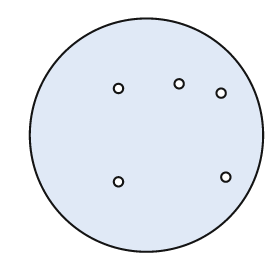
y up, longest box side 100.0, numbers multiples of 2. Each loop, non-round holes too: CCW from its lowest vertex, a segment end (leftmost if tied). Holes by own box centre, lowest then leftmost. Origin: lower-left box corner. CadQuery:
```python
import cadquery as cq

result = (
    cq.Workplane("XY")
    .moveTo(50.0, 50.0)
    .circle(50.0)
    .moveTo(38.0, 30.0)
    .circle(2.0)
    .moveTo(84.0, 32.0)
    .circle(2.0)
    .moveTo(82.0, 68.0)
    .circle(2.0)
    .moveTo(38.0, 70.0)
    .circle(2.0)
    .moveTo(64.0, 72.0)
    .circle(2.0)
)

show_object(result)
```